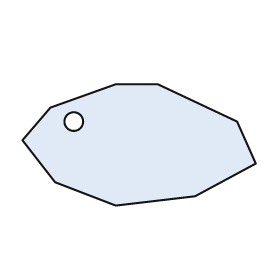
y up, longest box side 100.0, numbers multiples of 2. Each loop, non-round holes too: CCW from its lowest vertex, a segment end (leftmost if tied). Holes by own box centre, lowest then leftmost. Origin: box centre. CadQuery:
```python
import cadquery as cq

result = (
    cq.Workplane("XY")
    .moveTo(-10.0, -26.0)
    .lineTo(24.0, -22.0)
    .lineTo(50.0, -8.0)
    .lineTo(42.0, 10.0)
    .lineTo(8.0, 26.0)
    .lineTo(-10.0, 26.0)
    .lineTo(-38.0, 16.0)
    .lineTo(-50.0, 2.0)
    .lineTo(-36.0, -16.0)
    .close()
    .moveTo(-28.0, 10.0)
    .circle(4.0)
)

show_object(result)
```